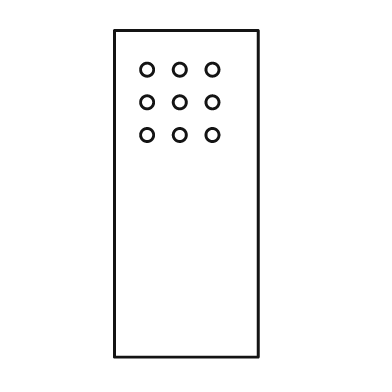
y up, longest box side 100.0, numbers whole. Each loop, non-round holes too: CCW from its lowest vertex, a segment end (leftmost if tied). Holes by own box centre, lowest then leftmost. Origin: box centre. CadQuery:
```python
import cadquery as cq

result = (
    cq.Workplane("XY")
    .moveTo(-22.0, -50.0)
    .lineTo(22.0, -50.0)
    .lineTo(22.0, 50.0)
    .lineTo(-22.0, 50.0)
    .close()
    .moveTo(-12.0, 18.0)
    .circle(2.0)
    .moveTo(-2.0, 18.0)
    .circle(2.0)
    .moveTo(8.0, 18.0)
    .circle(2.0)
    .moveTo(-12.0, 28.0)
    .circle(2.0)
    .moveTo(-2.0, 28.0)
    .circle(2.0)
    .moveTo(8.0, 28.0)
    .circle(2.0)
    .moveTo(-12.0, 38.0)
    .circle(2.0)
    .moveTo(-2.0, 38.0)
    .circle(2.0)
    .moveTo(8.0, 38.0)
    .circle(2.0)
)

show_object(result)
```